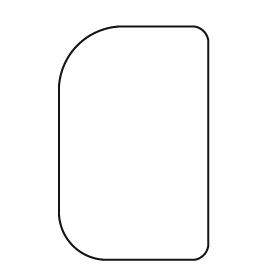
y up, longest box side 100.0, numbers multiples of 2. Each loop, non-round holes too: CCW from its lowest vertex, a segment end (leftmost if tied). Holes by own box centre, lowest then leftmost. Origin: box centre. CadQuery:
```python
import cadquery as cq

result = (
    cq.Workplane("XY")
    .moveTo(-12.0, -50.0)
    .lineTo(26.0, -50.0)
    .threePointArc((30.0, -48.0), (32.0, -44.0))
    .lineTo(32.0, 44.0)
    .threePointArc((30.0, 48.0), (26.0, 50.0))
    .lineTo(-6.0, 50.0)
    .threePointArc((-24.0, 42.0), (-32.0, 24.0))
    .lineTo(-32.0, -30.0)
    .threePointArc((-26.0, -44.0), (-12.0, -50.0))
    .close()
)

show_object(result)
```